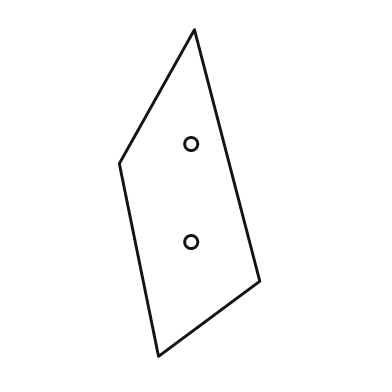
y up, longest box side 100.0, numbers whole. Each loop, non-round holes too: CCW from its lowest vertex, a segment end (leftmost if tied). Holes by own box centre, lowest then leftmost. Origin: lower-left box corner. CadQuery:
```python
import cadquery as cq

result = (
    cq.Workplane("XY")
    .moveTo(12.0, 0.0)
    .lineTo(43.0, 23.0)
    .lineTo(23.0, 100.0)
    .lineTo(0.0, 59.0)
    .close()
    .moveTo(22.0, 35.0)
    .circle(2.0)
    .moveTo(22.0, 65.0)
    .circle(2.0)
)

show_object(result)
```